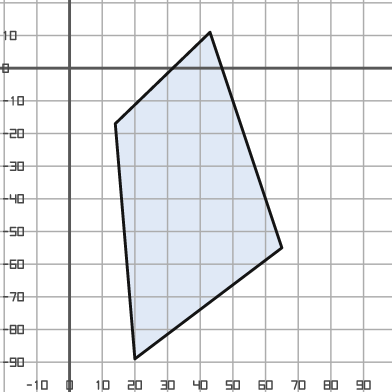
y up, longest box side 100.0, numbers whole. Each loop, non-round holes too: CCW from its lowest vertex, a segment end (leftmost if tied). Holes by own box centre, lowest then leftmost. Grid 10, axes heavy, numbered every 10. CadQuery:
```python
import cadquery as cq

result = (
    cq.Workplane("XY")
    .moveTo(20.0, -89.0)
    .lineTo(65.0, -55.0)
    .lineTo(43.0, 11.0)
    .lineTo(14.0, -17.0)
    .close()
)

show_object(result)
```